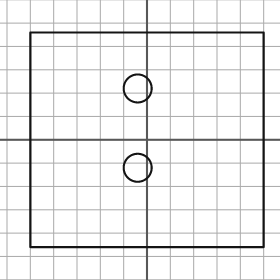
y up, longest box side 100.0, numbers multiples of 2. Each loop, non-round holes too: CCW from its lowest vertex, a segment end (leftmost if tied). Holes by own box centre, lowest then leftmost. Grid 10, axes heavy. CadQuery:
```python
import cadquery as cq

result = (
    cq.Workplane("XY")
    .moveTo(-50.0, -46.0)
    .lineTo(50.0, -46.0)
    .lineTo(50.0, 46.0)
    .lineTo(-50.0, 46.0)
    .close()
    .moveTo(-4.0, -12.0)
    .circle(6.0)
    .moveTo(-4.0, 22.0)
    .circle(6.0)
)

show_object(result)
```